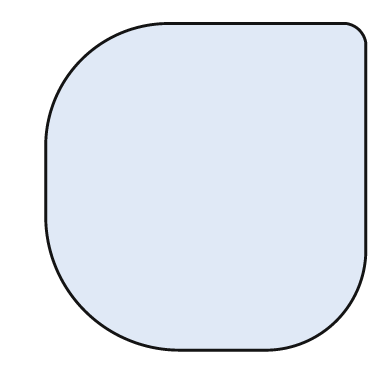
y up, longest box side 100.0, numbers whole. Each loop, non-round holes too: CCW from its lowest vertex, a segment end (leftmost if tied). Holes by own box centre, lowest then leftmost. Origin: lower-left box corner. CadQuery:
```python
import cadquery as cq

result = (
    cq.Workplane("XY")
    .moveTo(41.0, 0.0)
    .lineTo(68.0, 0.0)
    .threePointArc((89.0, 9.0), (98.0, 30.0))
    .lineTo(98.0, 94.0)
    .threePointArc((96.0, 98.0), (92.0, 100.0))
    .lineTo(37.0, 100.0)
    .threePointArc((11.0, 89.0), (0.0, 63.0))
    .lineTo(0.0, 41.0)
    .threePointArc((12.0, 12.0), (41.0, 0.0))
    .close()
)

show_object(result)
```